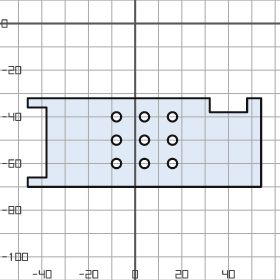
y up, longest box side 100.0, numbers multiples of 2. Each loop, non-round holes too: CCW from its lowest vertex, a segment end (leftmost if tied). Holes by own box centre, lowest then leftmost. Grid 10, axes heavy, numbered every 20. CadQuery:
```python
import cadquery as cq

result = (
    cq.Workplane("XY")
    .moveTo(-46.0, -70.0)
    .lineTo(54.0, -70.0)
    .lineTo(54.0, -32.0)
    .lineTo(48.0, -32.0)
    .lineTo(48.0, -38.0)
    .lineTo(32.0, -38.0)
    .lineTo(32.0, -32.0)
    .lineTo(-46.0, -32.0)
    .lineTo(-46.0, -36.0)
    .lineTo(-38.0, -36.0)
    .lineTo(-38.0, -66.0)
    .lineTo(-46.0, -66.0)
    .close()
    .moveTo(-8.0, -60.0)
    .circle(2.0)
    .moveTo(4.0, -60.0)
    .circle(2.0)
    .moveTo(16.0, -60.0)
    .circle(2.0)
    .moveTo(-8.0, -50.0)
    .circle(2.0)
    .moveTo(4.0, -50.0)
    .circle(2.0)
    .moveTo(16.0, -50.0)
    .circle(2.0)
    .moveTo(-8.0, -40.0)
    .circle(2.0)
    .moveTo(4.0, -40.0)
    .circle(2.0)
    .moveTo(16.0, -40.0)
    .circle(2.0)
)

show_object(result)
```